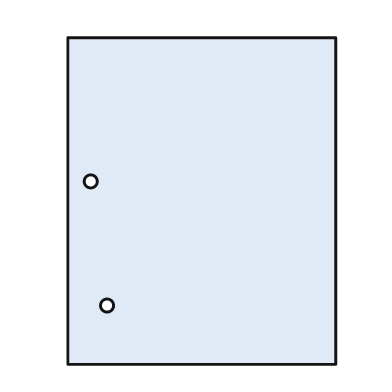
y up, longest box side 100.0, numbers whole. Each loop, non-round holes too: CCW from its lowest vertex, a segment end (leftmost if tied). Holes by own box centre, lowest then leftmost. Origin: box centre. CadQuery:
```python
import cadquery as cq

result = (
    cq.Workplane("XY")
    .moveTo(-41.0, -50.0)
    .lineTo(41.0, -50.0)
    .lineTo(41.0, 50.0)
    .lineTo(-41.0, 50.0)
    .close()
    .moveTo(-29.0, -32.0)
    .circle(2.0)
    .moveTo(-34.0, 6.0)
    .circle(2.0)
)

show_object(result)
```